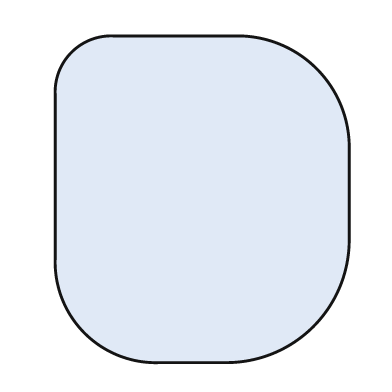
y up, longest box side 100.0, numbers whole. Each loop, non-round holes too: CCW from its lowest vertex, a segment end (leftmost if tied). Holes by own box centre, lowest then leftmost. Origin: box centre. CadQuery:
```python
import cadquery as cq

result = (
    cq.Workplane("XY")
    .moveTo(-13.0, -50.0)
    .lineTo(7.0, -50.0)
    .threePointArc((34.0, -39.0), (45.0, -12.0))
    .lineTo(45.0, 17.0)
    .threePointArc((35.0, 40.0), (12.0, 50.0))
    .lineTo(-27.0, 50.0)
    .threePointArc((-40.0, 45.0), (-45.0, 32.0))
    .lineTo(-45.0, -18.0)
    .threePointArc((-36.0, -41.0), (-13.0, -50.0))
    .close()
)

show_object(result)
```